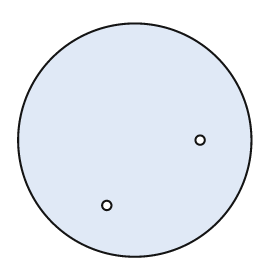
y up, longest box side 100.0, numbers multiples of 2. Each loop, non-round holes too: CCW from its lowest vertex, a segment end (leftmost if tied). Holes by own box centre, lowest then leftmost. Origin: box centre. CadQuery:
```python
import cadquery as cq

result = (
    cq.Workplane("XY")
    .moveTo(0.0, 0.0)
    .circle(50.0)
    .moveTo(-12.0, -28.0)
    .circle(2.0)
    .moveTo(28.0, 0.0)
    .circle(2.0)
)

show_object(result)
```